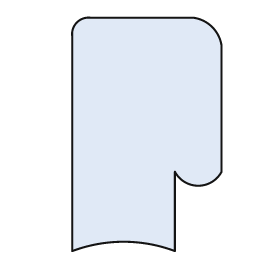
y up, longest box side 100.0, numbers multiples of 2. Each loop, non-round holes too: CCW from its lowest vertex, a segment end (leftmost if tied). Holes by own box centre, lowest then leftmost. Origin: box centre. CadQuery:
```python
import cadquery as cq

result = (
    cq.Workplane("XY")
    .moveTo(-32.0, -50.0)
    .threePointArc((-10.0, -46.0), (12.0, -50.0))
    .lineTo(12.0, -16.0)
    .threePointArc((22.0, -22.0), (32.0, -16.0))
    .lineTo(32.0, 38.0)
    .threePointArc((28.0, 46.0), (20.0, 50.0))
    .lineTo(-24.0, 50.0)
    .threePointArc((-30.0, 48.0), (-32.0, 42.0))
    .close()
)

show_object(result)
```